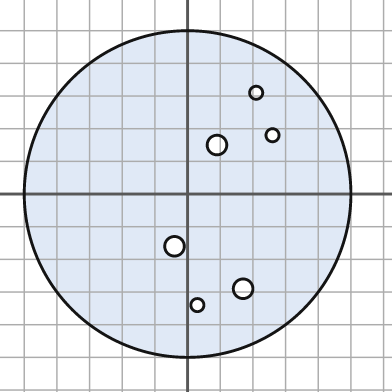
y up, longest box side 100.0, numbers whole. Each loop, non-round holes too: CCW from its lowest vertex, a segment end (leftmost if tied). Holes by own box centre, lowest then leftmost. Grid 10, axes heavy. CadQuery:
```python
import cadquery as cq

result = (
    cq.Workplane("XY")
    .moveTo(0.0, 0.0)
    .circle(50.0)
    .moveTo(3.0, -34.0)
    .circle(2.0)
    .moveTo(17.0, -29.0)
    .circle(3.0)
    .moveTo(-4.0, -16.0)
    .circle(3.0)
    .moveTo(9.0, 15.0)
    .circle(3.0)
    .moveTo(26.0, 18.0)
    .circle(2.0)
    .moveTo(21.0, 31.0)
    .circle(2.0)
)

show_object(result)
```